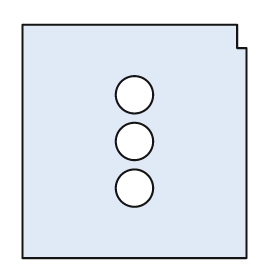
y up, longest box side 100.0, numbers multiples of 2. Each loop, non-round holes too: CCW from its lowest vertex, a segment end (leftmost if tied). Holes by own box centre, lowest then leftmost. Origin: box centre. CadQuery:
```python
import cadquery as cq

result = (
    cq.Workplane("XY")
    .moveTo(-48.0, -50.0)
    .lineTo(48.0, -50.0)
    .lineTo(48.0, 40.0)
    .lineTo(44.0, 40.0)
    .lineTo(44.0, 50.0)
    .lineTo(-48.0, 50.0)
    .close()
    .moveTo(0.0, -20.0)
    .circle(8.0)
    .moveTo(0.0, 0.0)
    .circle(8.0)
    .moveTo(0.0, 20.0)
    .circle(8.0)
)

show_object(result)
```